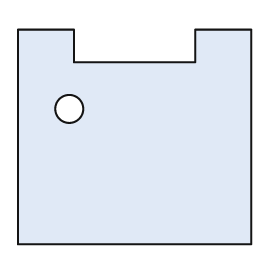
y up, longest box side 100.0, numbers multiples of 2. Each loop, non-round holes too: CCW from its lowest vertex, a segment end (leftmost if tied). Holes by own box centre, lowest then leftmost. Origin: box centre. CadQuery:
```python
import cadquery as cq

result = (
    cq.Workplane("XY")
    .moveTo(-50.0, -46.0)
    .lineTo(50.0, -46.0)
    .lineTo(50.0, 46.0)
    .lineTo(26.0, 46.0)
    .lineTo(26.0, 32.0)
    .lineTo(-26.0, 32.0)
    .lineTo(-26.0, 46.0)
    .lineTo(-50.0, 46.0)
    .close()
    .moveTo(-28.0, 12.0)
    .circle(6.0)
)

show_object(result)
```